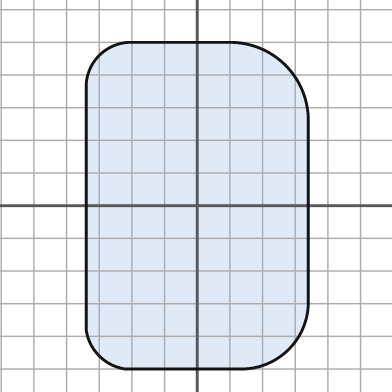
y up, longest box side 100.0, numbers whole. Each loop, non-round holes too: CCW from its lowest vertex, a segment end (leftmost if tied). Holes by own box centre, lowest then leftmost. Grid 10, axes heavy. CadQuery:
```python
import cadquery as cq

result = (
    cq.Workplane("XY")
    .moveTo(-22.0, -50.0)
    .lineTo(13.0, -50.0)
    .threePointArc((28.0, -44.0), (34.0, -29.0))
    .lineTo(34.0, 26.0)
    .threePointArc((27.0, 43.0), (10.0, 50.0))
    .lineTo(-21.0, 50.0)
    .threePointArc((-30.0, 46.0), (-34.0, 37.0))
    .lineTo(-34.0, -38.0)
    .threePointArc((-30.0, -46.0), (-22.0, -50.0))
    .close()
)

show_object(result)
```